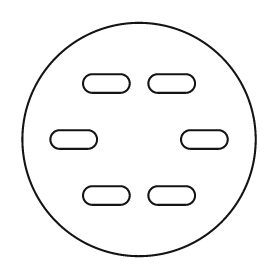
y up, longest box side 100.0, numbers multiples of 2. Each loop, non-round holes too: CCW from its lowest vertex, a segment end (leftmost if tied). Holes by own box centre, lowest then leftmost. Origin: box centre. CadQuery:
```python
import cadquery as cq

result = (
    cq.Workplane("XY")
    .moveTo(0.0, 0.0)
    .circle(50.0)
    .moveTo(-20.0, -28.0)
    .lineTo(-8.0, -28.0)
    .threePointArc((-4.0, -24.0), (-8.0, -20.0))
    .lineTo(-20.0, -20.0)
    .threePointArc((-24.0, -24.0), (-20.0, -28.0))
    .close()
    .moveTo(8.0, -28.0)
    .lineTo(20.0, -28.0)
    .threePointArc((24.0, -24.0), (20.0, -20.0))
    .lineTo(8.0, -20.0)
    .threePointArc((4.0, -24.0), (8.0, -28.0))
    .close()
    .moveTo(-34.0, -4.0)
    .lineTo(-22.0, -4.0)
    .threePointArc((-18.0, 0.0), (-22.0, 4.0))
    .lineTo(-34.0, 4.0)
    .threePointArc((-38.0, 0.0), (-34.0, -4.0))
    .close()
    .moveTo(22.0, -4.0)
    .lineTo(34.0, -4.0)
    .threePointArc((38.0, 0.0), (34.0, 4.0))
    .lineTo(22.0, 4.0)
    .threePointArc((18.0, 0.0), (22.0, -4.0))
    .close()
    .moveTo(-20.0, 20.0)
    .lineTo(-8.0, 20.0)
    .threePointArc((-4.0, 24.0), (-8.0, 28.0))
    .lineTo(-20.0, 28.0)
    .threePointArc((-24.0, 24.0), (-20.0, 20.0))
    .close()
    .moveTo(8.0, 20.0)
    .lineTo(20.0, 20.0)
    .threePointArc((24.0, 24.0), (20.0, 28.0))
    .lineTo(8.0, 28.0)
    .threePointArc((4.0, 24.0), (8.0, 20.0))
    .close()
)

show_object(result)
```